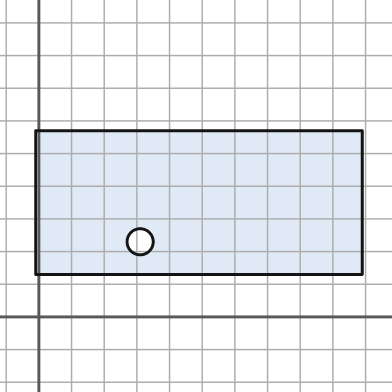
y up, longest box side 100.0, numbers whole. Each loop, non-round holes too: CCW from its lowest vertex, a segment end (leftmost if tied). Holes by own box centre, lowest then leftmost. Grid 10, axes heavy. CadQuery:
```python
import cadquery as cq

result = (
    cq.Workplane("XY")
    .moveTo(-1.0, 13.0)
    .lineTo(99.0, 13.0)
    .lineTo(99.0, 57.0)
    .lineTo(-1.0, 57.0)
    .close()
    .moveTo(31.0, 23.0)
    .circle(4.0)
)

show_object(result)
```